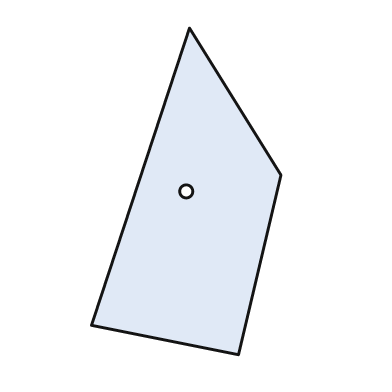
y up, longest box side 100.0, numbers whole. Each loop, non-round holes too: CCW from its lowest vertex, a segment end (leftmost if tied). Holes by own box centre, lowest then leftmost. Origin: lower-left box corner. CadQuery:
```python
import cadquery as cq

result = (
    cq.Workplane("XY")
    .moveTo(45.0, 0.0)
    .lineTo(58.0, 55.0)
    .lineTo(30.0, 100.0)
    .lineTo(0.0, 9.0)
    .close()
    .moveTo(29.0, 50.0)
    .circle(2.0)
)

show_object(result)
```